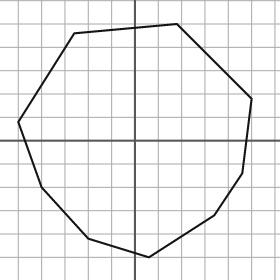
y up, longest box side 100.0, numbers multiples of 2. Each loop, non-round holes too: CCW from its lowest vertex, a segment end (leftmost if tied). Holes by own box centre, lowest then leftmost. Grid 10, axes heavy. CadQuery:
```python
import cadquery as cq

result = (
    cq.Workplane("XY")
    .moveTo(6.0, -50.0)
    .lineTo(34.0, -32.0)
    .lineTo(46.0, -14.0)
    .lineTo(50.0, 18.0)
    .lineTo(18.0, 50.0)
    .lineTo(-26.0, 46.0)
    .lineTo(-50.0, 8.0)
    .lineTo(-40.0, -20.0)
    .lineTo(-20.0, -42.0)
    .close()
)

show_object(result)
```